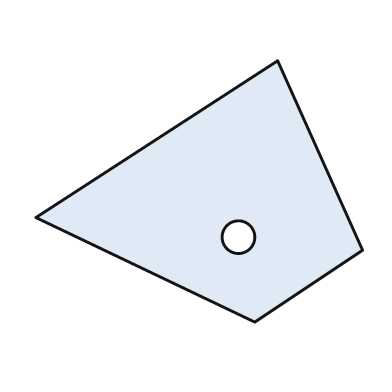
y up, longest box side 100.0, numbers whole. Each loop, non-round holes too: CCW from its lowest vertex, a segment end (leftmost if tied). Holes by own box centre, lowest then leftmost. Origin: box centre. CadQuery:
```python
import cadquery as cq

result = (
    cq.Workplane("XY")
    .moveTo(17.0, -40.0)
    .lineTo(50.0, -18.0)
    .lineTo(24.0, 40.0)
    .lineTo(-50.0, -8.0)
    .close()
    .moveTo(12.0, -14.0)
    .circle(5.0)
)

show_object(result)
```